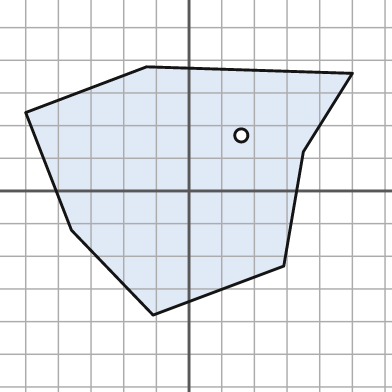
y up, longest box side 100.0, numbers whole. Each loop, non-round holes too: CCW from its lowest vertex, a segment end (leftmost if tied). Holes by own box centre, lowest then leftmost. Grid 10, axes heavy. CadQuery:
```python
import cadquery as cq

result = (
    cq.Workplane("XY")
    .moveTo(-11.0, -38.0)
    .lineTo(29.0, -23.0)
    .lineTo(35.0, 12.0)
    .lineTo(50.0, 36.0)
    .lineTo(-13.0, 38.0)
    .lineTo(-50.0, 24.0)
    .lineTo(-36.0, -12.0)
    .close()
    .moveTo(16.0, 17.0)
    .circle(2.0)
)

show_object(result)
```